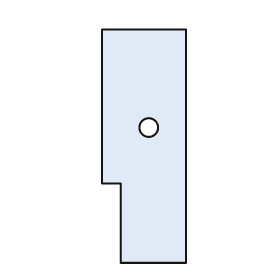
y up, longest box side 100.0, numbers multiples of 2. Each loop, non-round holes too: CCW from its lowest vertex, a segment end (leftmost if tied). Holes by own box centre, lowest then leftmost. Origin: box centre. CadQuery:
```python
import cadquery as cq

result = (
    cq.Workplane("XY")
    .moveTo(-10.0, -50.0)
    .lineTo(18.0, -50.0)
    .lineTo(18.0, 50.0)
    .lineTo(-18.0, 50.0)
    .lineTo(-18.0, -16.0)
    .lineTo(-10.0, -16.0)
    .close()
    .moveTo(2.0, 8.0)
    .circle(4.0)
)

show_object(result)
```